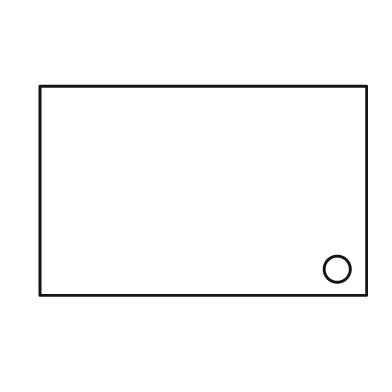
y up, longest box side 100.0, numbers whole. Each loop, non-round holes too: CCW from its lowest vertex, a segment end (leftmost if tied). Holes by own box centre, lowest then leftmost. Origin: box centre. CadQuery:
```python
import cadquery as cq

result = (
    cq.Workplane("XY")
    .moveTo(-50.0, -32.0)
    .lineTo(50.0, -32.0)
    .lineTo(50.0, 32.0)
    .lineTo(-50.0, 32.0)
    .close()
    .moveTo(41.0, -24.0)
    .circle(4.0)
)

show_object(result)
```